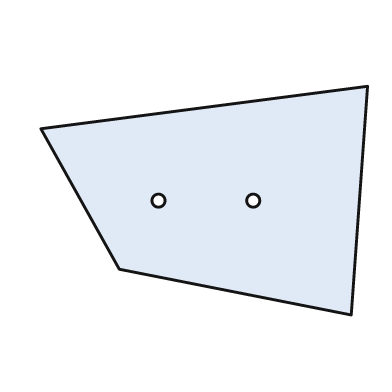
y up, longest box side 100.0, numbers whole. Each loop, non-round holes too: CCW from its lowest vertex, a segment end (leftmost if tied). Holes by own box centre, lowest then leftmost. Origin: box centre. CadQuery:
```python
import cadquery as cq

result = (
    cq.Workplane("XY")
    .moveTo(45.0, -35.0)
    .lineTo(50.0, 35.0)
    .lineTo(-50.0, 22.0)
    .lineTo(-26.0, -21.0)
    .close()
    .moveTo(-14.0, 0.0)
    .circle(2.0)
    .moveTo(15.0, 0.0)
    .circle(2.0)
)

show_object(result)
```